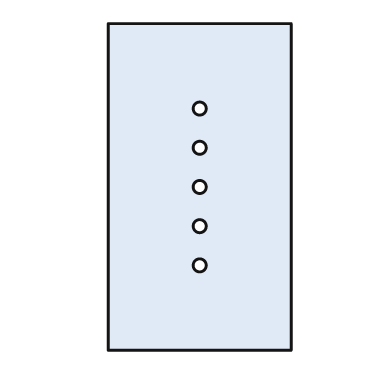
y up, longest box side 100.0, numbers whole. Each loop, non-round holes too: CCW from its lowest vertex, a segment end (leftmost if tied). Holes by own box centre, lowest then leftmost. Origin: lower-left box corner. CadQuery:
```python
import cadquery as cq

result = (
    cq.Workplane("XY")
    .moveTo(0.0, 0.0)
    .lineTo(56.0, 0.0)
    .lineTo(56.0, 100.0)
    .lineTo(0.0, 100.0)
    .close()
    .moveTo(28.0, 26.0)
    .circle(2.0)
    .moveTo(28.0, 38.0)
    .circle(2.0)
    .moveTo(28.0, 50.0)
    .circle(2.0)
    .moveTo(28.0, 62.0)
    .circle(2.0)
    .moveTo(28.0, 74.0)
    .circle(2.0)
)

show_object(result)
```